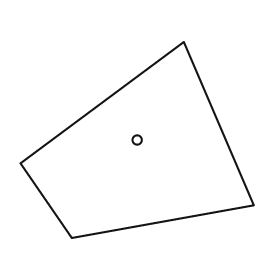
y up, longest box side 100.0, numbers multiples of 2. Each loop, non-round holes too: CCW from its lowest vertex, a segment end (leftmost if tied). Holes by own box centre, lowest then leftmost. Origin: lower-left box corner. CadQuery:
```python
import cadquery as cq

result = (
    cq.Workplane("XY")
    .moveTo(22.0, 0.0)
    .lineTo(100.0, 14.0)
    .lineTo(70.0, 84.0)
    .lineTo(0.0, 32.0)
    .close()
    .moveTo(50.0, 42.0)
    .circle(2.0)
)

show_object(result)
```